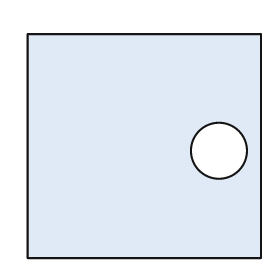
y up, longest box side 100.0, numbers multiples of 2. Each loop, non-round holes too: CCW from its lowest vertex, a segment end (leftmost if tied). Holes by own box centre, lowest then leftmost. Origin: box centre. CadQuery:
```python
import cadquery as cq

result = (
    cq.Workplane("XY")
    .moveTo(-50.0, -48.0)
    .lineTo(50.0, -48.0)
    .lineTo(50.0, 48.0)
    .lineTo(-50.0, 48.0)
    .close()
    .moveTo(32.0, -2.0)
    .circle(12.0)
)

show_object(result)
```